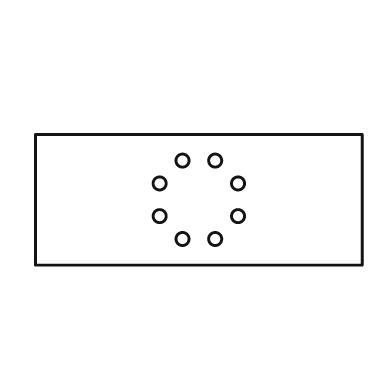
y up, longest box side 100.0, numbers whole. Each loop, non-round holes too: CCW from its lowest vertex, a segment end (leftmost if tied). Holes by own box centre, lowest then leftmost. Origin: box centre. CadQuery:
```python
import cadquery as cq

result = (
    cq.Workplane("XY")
    .moveTo(-50.0, -20.0)
    .lineTo(50.0, -20.0)
    .lineTo(50.0, 20.0)
    .lineTo(-50.0, 20.0)
    .close()
    .moveTo(-5.0, -12.0)
    .circle(2.0)
    .moveTo(5.0, -12.0)
    .circle(2.0)
    .moveTo(-12.0, -5.0)
    .circle(2.0)
    .moveTo(12.0, -5.0)
    .circle(2.0)
    .moveTo(-12.0, 5.0)
    .circle(2.0)
    .moveTo(12.0, 5.0)
    .circle(2.0)
    .moveTo(-5.0, 12.0)
    .circle(2.0)
    .moveTo(5.0, 12.0)
    .circle(2.0)
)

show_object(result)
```